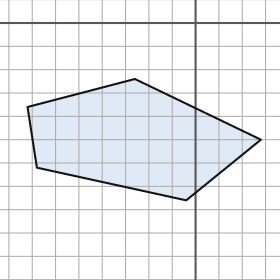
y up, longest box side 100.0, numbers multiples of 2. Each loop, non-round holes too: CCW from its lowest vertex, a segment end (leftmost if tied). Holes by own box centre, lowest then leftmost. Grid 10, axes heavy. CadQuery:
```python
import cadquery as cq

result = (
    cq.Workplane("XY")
    .moveTo(-4.0, -76.0)
    .lineTo(28.0, -50.0)
    .lineTo(-26.0, -24.0)
    .lineTo(-72.0, -36.0)
    .lineTo(-68.0, -62.0)
    .close()
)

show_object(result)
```